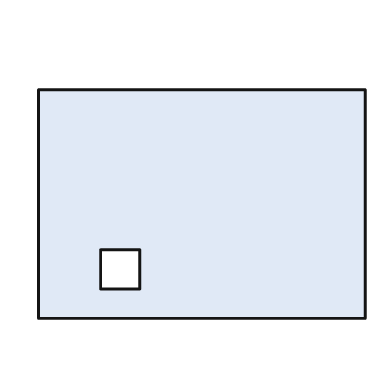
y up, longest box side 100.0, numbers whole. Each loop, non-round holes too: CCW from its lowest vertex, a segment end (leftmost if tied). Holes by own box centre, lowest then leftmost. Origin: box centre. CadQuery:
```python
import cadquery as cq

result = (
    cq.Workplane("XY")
    .moveTo(-50.0, -35.0)
    .lineTo(50.0, -35.0)
    .lineTo(50.0, 35.0)
    .lineTo(-50.0, 35.0)
    .close()
    .moveTo(-31.0, -26.0)
    .lineTo(-19.0, -26.0)
    .lineTo(-19.0, -14.0)
    .lineTo(-31.0, -14.0)
    .close()
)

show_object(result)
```